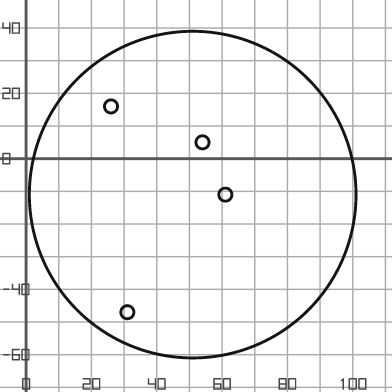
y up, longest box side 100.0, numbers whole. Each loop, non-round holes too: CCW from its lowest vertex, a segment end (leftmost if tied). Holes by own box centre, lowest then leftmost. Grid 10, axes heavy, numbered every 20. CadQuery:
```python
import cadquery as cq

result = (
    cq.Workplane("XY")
    .moveTo(51.0, -11.0)
    .circle(50.0)
    .moveTo(31.0, -47.0)
    .circle(2.0)
    .moveTo(61.0, -11.0)
    .circle(2.0)
    .moveTo(54.0, 5.0)
    .circle(2.0)
    .moveTo(26.0, 16.0)
    .circle(2.0)
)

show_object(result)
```